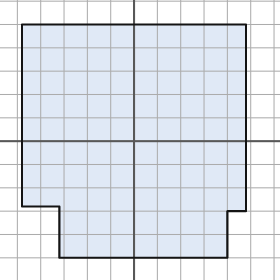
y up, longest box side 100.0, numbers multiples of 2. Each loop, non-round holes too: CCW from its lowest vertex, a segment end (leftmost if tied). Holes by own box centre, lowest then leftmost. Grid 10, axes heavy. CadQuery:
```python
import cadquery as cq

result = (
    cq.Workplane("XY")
    .moveTo(-32.0, -50.0)
    .lineTo(40.0, -50.0)
    .lineTo(40.0, -30.0)
    .lineTo(48.0, -30.0)
    .lineTo(48.0, 50.0)
    .lineTo(-48.0, 50.0)
    .lineTo(-48.0, -28.0)
    .lineTo(-32.0, -28.0)
    .close()
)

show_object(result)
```